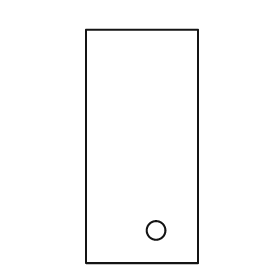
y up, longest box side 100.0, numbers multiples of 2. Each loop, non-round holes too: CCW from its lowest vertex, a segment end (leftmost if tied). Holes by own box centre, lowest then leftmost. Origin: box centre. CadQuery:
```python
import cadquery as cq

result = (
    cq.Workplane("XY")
    .moveTo(-24.0, -50.0)
    .lineTo(24.0, -50.0)
    .lineTo(24.0, 50.0)
    .lineTo(-24.0, 50.0)
    .close()
    .moveTo(6.0, -36.0)
    .circle(4.0)
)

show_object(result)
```